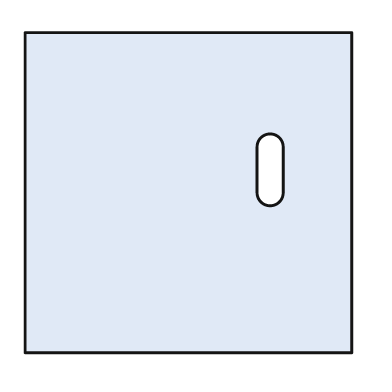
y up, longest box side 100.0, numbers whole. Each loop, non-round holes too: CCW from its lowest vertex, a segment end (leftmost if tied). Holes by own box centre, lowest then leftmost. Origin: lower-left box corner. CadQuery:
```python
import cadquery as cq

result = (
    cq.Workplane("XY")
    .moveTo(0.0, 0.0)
    .lineTo(100.0, 0.0)
    .lineTo(100.0, 98.0)
    .lineTo(0.0, 98.0)
    .close()
    .moveTo(71.0, 49.0)
    .threePointArc((75.0, 45.0), (79.0, 49.0))
    .lineTo(79.0, 63.0)
    .threePointArc((75.0, 67.0), (71.0, 63.0))
    .close()
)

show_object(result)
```